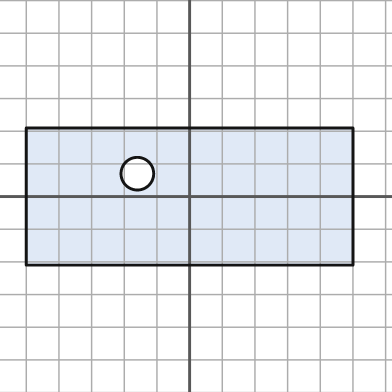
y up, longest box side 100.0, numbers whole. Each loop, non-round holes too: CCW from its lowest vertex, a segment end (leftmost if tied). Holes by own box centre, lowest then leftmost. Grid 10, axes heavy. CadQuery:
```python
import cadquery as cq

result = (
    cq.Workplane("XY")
    .moveTo(-50.0, -21.0)
    .lineTo(50.0, -21.0)
    .lineTo(50.0, 21.0)
    .lineTo(-50.0, 21.0)
    .close()
    .moveTo(-16.0, 7.0)
    .circle(5.0)
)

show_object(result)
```